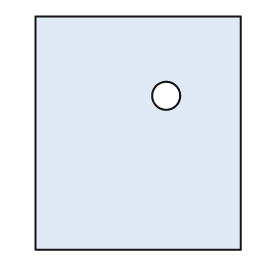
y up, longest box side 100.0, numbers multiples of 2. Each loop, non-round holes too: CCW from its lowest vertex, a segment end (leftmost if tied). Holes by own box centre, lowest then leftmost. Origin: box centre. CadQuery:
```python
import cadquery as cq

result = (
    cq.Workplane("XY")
    .moveTo(-44.0, -50.0)
    .lineTo(44.0, -50.0)
    .lineTo(44.0, 50.0)
    .lineTo(-44.0, 50.0)
    .close()
    .moveTo(12.0, 16.0)
    .circle(6.0)
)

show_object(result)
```